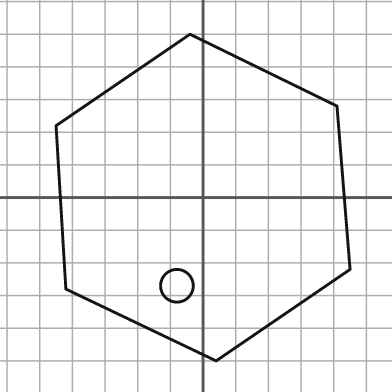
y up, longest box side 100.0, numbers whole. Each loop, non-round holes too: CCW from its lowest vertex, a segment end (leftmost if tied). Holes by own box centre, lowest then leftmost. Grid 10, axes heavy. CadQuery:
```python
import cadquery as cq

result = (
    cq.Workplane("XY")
    .moveTo(4.0, -50.0)
    .lineTo(45.0, -22.0)
    .lineTo(41.0, 28.0)
    .lineTo(-4.0, 50.0)
    .lineTo(-45.0, 22.0)
    .lineTo(-42.0, -28.0)
    .close()
    .moveTo(-8.0, -27.0)
    .circle(5.0)
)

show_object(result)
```